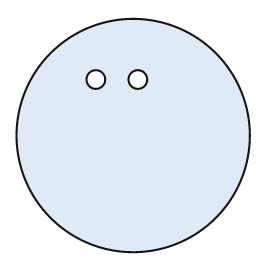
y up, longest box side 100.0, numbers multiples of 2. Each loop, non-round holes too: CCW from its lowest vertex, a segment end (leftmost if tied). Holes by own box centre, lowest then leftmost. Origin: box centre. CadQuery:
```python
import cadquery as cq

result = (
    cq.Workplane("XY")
    .moveTo(0.0, 0.0)
    .circle(50.0)
    .moveTo(-16.0, 24.0)
    .circle(4.0)
    .moveTo(2.0, 24.0)
    .circle(4.0)
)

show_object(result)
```